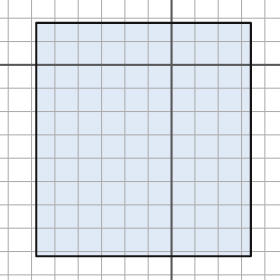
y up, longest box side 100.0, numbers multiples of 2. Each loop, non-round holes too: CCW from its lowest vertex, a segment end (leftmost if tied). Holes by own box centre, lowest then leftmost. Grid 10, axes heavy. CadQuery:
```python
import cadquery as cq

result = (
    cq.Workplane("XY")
    .moveTo(-58.0, -82.0)
    .lineTo(34.0, -82.0)
    .lineTo(34.0, 18.0)
    .lineTo(-58.0, 18.0)
    .close()
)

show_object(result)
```